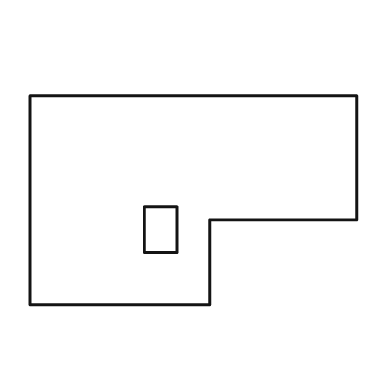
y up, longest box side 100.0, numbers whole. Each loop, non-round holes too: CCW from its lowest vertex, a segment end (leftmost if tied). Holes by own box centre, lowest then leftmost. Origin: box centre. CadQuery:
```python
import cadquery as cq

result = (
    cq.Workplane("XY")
    .moveTo(-50.0, -32.0)
    .lineTo(5.0, -32.0)
    .lineTo(5.0, -6.0)
    .lineTo(50.0, -6.0)
    .lineTo(50.0, 32.0)
    .lineTo(-50.0, 32.0)
    .close()
    .moveTo(-15.0, -16.0)
    .lineTo(-5.0, -16.0)
    .lineTo(-5.0, -2.0)
    .lineTo(-15.0, -2.0)
    .close()
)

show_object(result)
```